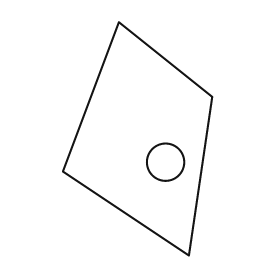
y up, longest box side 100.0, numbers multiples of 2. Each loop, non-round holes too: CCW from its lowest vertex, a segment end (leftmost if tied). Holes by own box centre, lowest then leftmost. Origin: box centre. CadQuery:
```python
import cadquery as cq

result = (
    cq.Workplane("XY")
    .moveTo(22.0, -50.0)
    .lineTo(32.0, 18.0)
    .lineTo(-8.0, 50.0)
    .lineTo(-32.0, -14.0)
    .close()
    .moveTo(12.0, -10.0)
    .circle(8.0)
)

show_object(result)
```